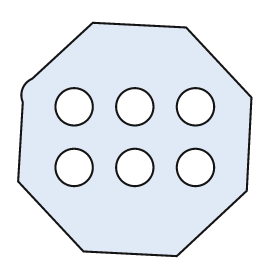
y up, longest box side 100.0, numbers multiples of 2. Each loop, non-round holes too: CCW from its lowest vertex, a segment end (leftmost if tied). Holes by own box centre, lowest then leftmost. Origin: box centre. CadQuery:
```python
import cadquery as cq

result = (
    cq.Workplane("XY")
    .moveTo(18.0, -50.0)
    .lineTo(48.0, -22.0)
    .lineTo(50.0, 18.0)
    .lineTo(22.0, 48.0)
    .lineTo(-18.0, 50.0)
    .lineTo(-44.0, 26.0)
    .threePointArc((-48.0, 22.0), (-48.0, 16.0))
    .lineTo(-50.0, -18.0)
    .lineTo(-22.0, -48.0)
    .close()
    .moveTo(-26.0, -12.0)
    .circle(8.0)
    .moveTo(0.0, -12.0)
    .circle(8.0)
    .moveTo(26.0, -12.0)
    .circle(8.0)
    .moveTo(-26.0, 14.0)
    .circle(8.0)
    .moveTo(0.0, 14.0)
    .circle(8.0)
    .moveTo(26.0, 14.0)
    .circle(8.0)
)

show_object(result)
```